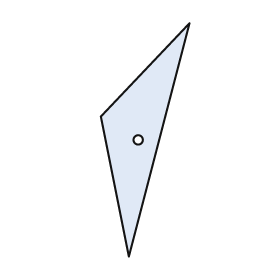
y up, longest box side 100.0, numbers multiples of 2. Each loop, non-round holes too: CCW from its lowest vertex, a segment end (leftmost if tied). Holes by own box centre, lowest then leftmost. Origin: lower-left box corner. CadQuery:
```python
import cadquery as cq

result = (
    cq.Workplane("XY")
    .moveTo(12.0, 0.0)
    .lineTo(38.0, 100.0)
    .lineTo(0.0, 60.0)
    .close()
    .moveTo(16.0, 50.0)
    .circle(2.0)
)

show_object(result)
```